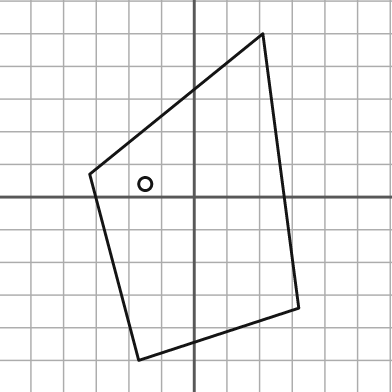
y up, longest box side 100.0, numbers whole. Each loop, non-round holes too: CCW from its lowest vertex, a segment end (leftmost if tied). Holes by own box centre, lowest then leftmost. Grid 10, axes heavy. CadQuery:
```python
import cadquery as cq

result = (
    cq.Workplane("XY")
    .moveTo(-17.0, -50.0)
    .lineTo(32.0, -34.0)
    .lineTo(21.0, 50.0)
    .lineTo(-32.0, 7.0)
    .close()
    .moveTo(-15.0, 4.0)
    .circle(2.0)
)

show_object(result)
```